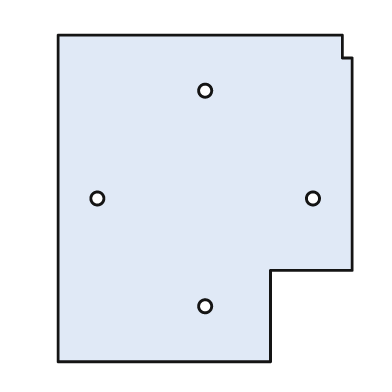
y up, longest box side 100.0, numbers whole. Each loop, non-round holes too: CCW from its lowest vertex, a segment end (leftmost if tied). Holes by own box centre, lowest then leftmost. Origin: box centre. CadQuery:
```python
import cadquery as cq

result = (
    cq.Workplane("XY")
    .moveTo(-45.0, -50.0)
    .lineTo(20.0, -50.0)
    .lineTo(20.0, -22.0)
    .lineTo(45.0, -22.0)
    .lineTo(45.0, 43.0)
    .lineTo(42.0, 43.0)
    .lineTo(42.0, 50.0)
    .lineTo(-45.0, 50.0)
    .close()
    .moveTo(0.0, -33.0)
    .circle(2.0)
    .moveTo(-33.0, 0.0)
    .circle(2.0)
    .moveTo(33.0, 0.0)
    .circle(2.0)
    .moveTo(0.0, 33.0)
    .circle(2.0)
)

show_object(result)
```